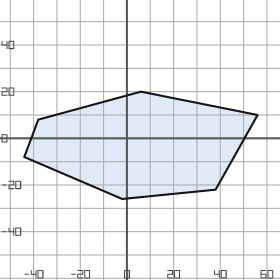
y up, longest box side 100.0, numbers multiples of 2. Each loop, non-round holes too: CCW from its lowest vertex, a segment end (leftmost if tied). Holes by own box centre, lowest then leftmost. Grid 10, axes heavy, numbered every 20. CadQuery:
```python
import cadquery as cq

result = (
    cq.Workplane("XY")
    .moveTo(-2.0, -26.0)
    .lineTo(38.0, -22.0)
    .lineTo(56.0, 10.0)
    .lineTo(6.0, 20.0)
    .lineTo(-38.0, 8.0)
    .lineTo(-44.0, -8.0)
    .close()
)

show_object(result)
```